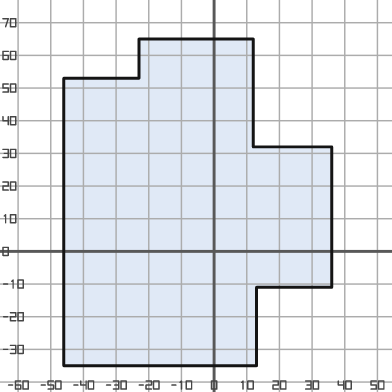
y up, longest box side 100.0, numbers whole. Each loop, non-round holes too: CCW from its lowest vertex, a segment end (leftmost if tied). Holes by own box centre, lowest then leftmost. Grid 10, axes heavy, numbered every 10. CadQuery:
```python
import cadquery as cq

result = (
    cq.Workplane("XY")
    .moveTo(-46.0, -35.0)
    .lineTo(13.0, -35.0)
    .lineTo(13.0, -11.0)
    .lineTo(36.0, -11.0)
    .lineTo(36.0, 32.0)
    .lineTo(12.0, 32.0)
    .lineTo(12.0, 65.0)
    .lineTo(-23.0, 65.0)
    .lineTo(-23.0, 53.0)
    .lineTo(-46.0, 53.0)
    .close()
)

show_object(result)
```